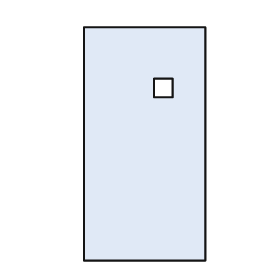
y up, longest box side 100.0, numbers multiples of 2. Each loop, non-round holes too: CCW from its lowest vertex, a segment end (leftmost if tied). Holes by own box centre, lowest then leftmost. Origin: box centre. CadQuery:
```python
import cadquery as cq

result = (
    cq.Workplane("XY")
    .moveTo(-26.0, -50.0)
    .lineTo(26.0, -50.0)
    .lineTo(26.0, 50.0)
    .lineTo(-26.0, 50.0)
    .close()
    .moveTo(4.0, 20.0)
    .lineTo(12.0, 20.0)
    .lineTo(12.0, 28.0)
    .lineTo(4.0, 28.0)
    .close()
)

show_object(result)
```